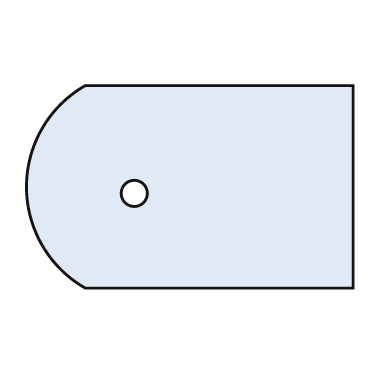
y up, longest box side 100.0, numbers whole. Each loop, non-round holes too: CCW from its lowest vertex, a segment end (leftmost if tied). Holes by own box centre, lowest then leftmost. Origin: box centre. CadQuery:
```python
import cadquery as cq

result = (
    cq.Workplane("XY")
    .moveTo(-32.0, -31.0)
    .lineTo(50.0, -31.0)
    .lineTo(50.0, 31.0)
    .lineTo(-32.0, 31.0)
    .threePointArc((-50.0, 0.0), (-32.0, -31.0))
    .close()
    .moveTo(-17.0, -2.0)
    .circle(4.0)
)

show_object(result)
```